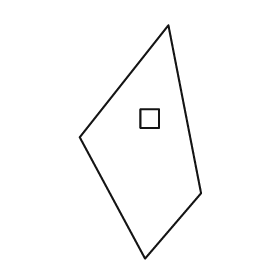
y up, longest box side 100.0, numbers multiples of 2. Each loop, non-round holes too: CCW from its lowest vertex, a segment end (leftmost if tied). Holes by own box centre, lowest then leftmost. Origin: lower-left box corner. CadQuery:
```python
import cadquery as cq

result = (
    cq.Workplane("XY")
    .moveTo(28.0, 0.0)
    .lineTo(52.0, 28.0)
    .lineTo(38.0, 100.0)
    .lineTo(0.0, 52.0)
    .close()
    .moveTo(26.0, 56.0)
    .lineTo(34.0, 56.0)
    .lineTo(34.0, 64.0)
    .lineTo(26.0, 64.0)
    .close()
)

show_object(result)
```